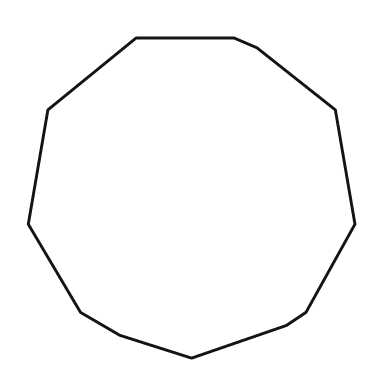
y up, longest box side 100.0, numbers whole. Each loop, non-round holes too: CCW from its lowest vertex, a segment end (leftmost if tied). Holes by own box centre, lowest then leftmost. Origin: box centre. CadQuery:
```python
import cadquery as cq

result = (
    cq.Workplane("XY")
    .moveTo(0.0, -49.0)
    .lineTo(29.0, -39.0)
    .lineTo(35.0, -35.0)
    .lineTo(50.0, -8.0)
    .lineTo(44.0, 27.0)
    .lineTo(20.0, 46.0)
    .lineTo(13.0, 49.0)
    .lineTo(-17.0, 49.0)
    .lineTo(-44.0, 27.0)
    .lineTo(-50.0, -8.0)
    .lineTo(-34.0, -35.0)
    .lineTo(-22.0, -42.0)
    .close()
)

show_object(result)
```